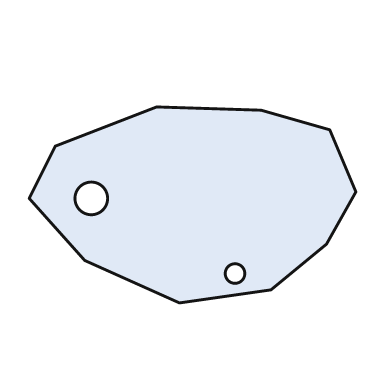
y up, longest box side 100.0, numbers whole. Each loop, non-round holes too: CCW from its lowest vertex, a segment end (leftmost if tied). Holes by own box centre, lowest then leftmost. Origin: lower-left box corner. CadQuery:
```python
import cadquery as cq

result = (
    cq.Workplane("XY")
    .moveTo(46.0, 0.0)
    .lineTo(74.0, 4.0)
    .lineTo(91.0, 18.0)
    .lineTo(100.0, 34.0)
    .lineTo(92.0, 53.0)
    .lineTo(71.0, 59.0)
    .lineTo(39.0, 60.0)
    .lineTo(8.0, 48.0)
    .lineTo(0.0, 32.0)
    .lineTo(17.0, 13.0)
    .close()
    .moveTo(63.0, 9.0)
    .circle(3.0)
    .moveTo(19.0, 32.0)
    .circle(5.0)
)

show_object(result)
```